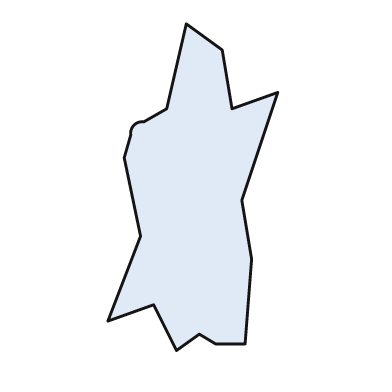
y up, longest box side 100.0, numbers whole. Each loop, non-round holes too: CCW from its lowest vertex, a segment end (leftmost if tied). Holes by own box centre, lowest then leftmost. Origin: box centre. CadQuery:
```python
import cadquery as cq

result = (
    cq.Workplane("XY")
    .moveTo(-5.0, -50.0)
    .lineTo(2.0, -45.0)
    .lineTo(7.0, -48.0)
    .lineTo(16.0, -48.0)
    .lineTo(18.0, -22.0)
    .lineTo(15.0, -4.0)
    .lineTo(26.0, 29.0)
    .lineTo(12.0, 24.0)
    .lineTo(9.0, 42.0)
    .lineTo(-2.0, 50.0)
    .lineTo(-8.0, 24.0)
    .lineTo(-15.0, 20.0)
    .threePointArc((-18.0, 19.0), (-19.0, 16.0))
    .lineTo(-21.0, 9.0)
    .lineTo(-16.0, -15.0)
    .lineTo(-26.0, -41.0)
    .lineTo(-12.0, -36.0)
    .close()
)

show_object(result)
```